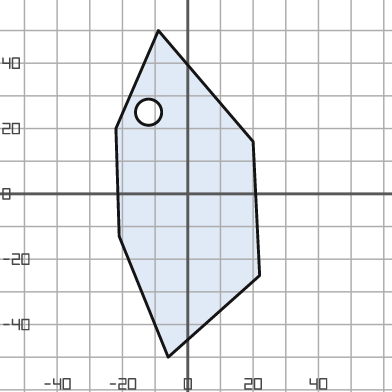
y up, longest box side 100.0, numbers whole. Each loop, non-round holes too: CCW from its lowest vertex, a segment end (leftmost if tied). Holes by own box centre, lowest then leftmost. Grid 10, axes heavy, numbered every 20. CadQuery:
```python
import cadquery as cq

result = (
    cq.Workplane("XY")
    .moveTo(-6.0, -50.0)
    .lineTo(22.0, -25.0)
    .lineTo(20.0, 16.0)
    .lineTo(-9.0, 50.0)
    .lineTo(-22.0, 20.0)
    .lineTo(-21.0, -13.0)
    .close()
    .moveTo(-12.0, 25.0)
    .circle(4.0)
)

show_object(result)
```